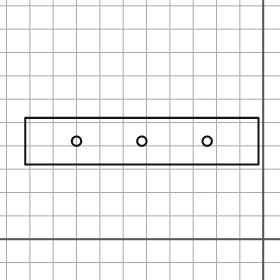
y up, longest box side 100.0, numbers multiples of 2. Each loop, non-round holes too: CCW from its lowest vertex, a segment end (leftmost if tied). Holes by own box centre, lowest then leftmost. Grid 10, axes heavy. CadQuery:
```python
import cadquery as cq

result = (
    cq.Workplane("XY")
    .moveTo(-102.0, 32.0)
    .lineTo(-2.0, 32.0)
    .lineTo(-2.0, 52.0)
    .lineTo(-102.0, 52.0)
    .close()
    .moveTo(-80.0, 42.0)
    .circle(2.0)
    .moveTo(-52.0, 42.0)
    .circle(2.0)
    .moveTo(-24.0, 42.0)
    .circle(2.0)
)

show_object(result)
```